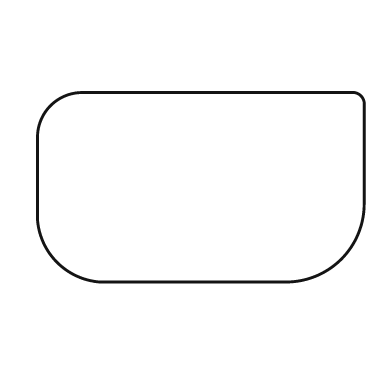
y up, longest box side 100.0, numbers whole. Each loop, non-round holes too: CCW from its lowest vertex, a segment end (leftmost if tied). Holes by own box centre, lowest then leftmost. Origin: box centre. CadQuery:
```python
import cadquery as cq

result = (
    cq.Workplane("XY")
    .moveTo(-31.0, -29.0)
    .lineTo(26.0, -29.0)
    .threePointArc((43.0, -22.0), (50.0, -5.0))
    .lineTo(50.0, 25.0)
    .threePointArc((49.0, 28.0), (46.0, 29.0))
    .lineTo(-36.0, 29.0)
    .threePointArc((-46.0, 25.0), (-50.0, 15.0))
    .lineTo(-50.0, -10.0)
    .threePointArc((-44.0, -23.0), (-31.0, -29.0))
    .close()
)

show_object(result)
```